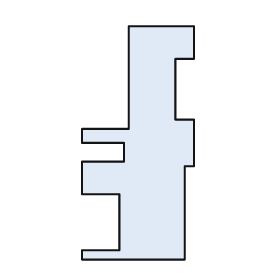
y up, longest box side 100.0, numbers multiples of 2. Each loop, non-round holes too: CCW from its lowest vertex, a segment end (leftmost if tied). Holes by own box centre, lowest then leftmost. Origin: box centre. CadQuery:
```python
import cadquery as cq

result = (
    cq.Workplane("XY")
    .moveTo(-24.0, -50.0)
    .lineTo(20.0, -50.0)
    .lineTo(20.0, -10.0)
    .lineTo(24.0, -10.0)
    .lineTo(24.0, 10.0)
    .lineTo(16.0, 10.0)
    .lineTo(16.0, 36.0)
    .lineTo(24.0, 36.0)
    .lineTo(24.0, 50.0)
    .lineTo(-4.0, 50.0)
    .lineTo(-4.0, 6.0)
    .lineTo(-24.0, 6.0)
    .lineTo(-24.0, 0.0)
    .lineTo(-6.0, 0.0)
    .lineTo(-6.0, -8.0)
    .lineTo(-24.0, -8.0)
    .lineTo(-24.0, -22.0)
    .lineTo(-8.0, -22.0)
    .lineTo(-8.0, -46.0)
    .lineTo(-24.0, -46.0)
    .close()
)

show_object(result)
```